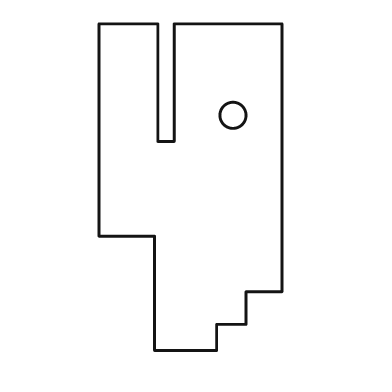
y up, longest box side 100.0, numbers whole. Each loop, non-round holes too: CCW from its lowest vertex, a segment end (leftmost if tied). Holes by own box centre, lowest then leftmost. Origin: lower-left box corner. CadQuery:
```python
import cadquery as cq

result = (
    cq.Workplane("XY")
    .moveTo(17.0, 0.0)
    .lineTo(36.0, 0.0)
    .lineTo(36.0, 8.0)
    .lineTo(45.0, 8.0)
    .lineTo(45.0, 18.0)
    .lineTo(56.0, 18.0)
    .lineTo(56.0, 100.0)
    .lineTo(23.0, 100.0)
    .lineTo(23.0, 64.0)
    .lineTo(18.0, 64.0)
    .lineTo(18.0, 100.0)
    .lineTo(0.0, 100.0)
    .lineTo(0.0, 35.0)
    .lineTo(17.0, 35.0)
    .close()
    .moveTo(41.0, 72.0)
    .circle(4.0)
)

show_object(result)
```